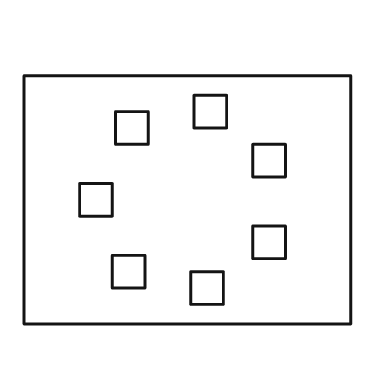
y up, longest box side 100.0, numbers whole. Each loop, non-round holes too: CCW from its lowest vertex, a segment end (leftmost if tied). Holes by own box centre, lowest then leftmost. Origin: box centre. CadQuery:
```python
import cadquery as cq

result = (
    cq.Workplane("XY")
    .moveTo(-50.0, -38.0)
    .lineTo(50.0, -38.0)
    .lineTo(50.0, 38.0)
    .lineTo(-50.0, 38.0)
    .close()
    .moveTo(1.0, -32.0)
    .lineTo(11.0, -32.0)
    .lineTo(11.0, -22.0)
    .lineTo(1.0, -22.0)
    .close()
    .moveTo(-23.0, -27.0)
    .lineTo(-13.0, -27.0)
    .lineTo(-13.0, -17.0)
    .lineTo(-23.0, -17.0)
    .close()
    .moveTo(20.0, -18.0)
    .lineTo(30.0, -18.0)
    .lineTo(30.0, -8.0)
    .lineTo(20.0, -8.0)
    .close()
    .moveTo(-33.0, -5.0)
    .lineTo(-23.0, -5.0)
    .lineTo(-23.0, 5.0)
    .lineTo(-33.0, 5.0)
    .close()
    .moveTo(20.0, 7.0)
    .lineTo(30.0, 7.0)
    .lineTo(30.0, 17.0)
    .lineTo(20.0, 17.0)
    .close()
    .moveTo(-22.0, 17.0)
    .lineTo(-12.0, 17.0)
    .lineTo(-12.0, 27.0)
    .lineTo(-22.0, 27.0)
    .close()
    .moveTo(2.0, 22.0)
    .lineTo(12.0, 22.0)
    .lineTo(12.0, 32.0)
    .lineTo(2.0, 32.0)
    .close()
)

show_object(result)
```